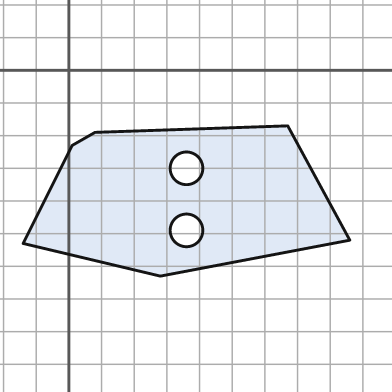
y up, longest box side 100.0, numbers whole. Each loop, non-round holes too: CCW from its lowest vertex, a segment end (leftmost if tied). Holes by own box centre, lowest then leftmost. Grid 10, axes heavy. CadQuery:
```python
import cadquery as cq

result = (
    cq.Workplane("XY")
    .moveTo(28.0, -63.0)
    .lineTo(86.0, -52.0)
    .lineTo(67.0, -17.0)
    .lineTo(8.0, -19.0)
    .lineTo(1.0, -23.0)
    .lineTo(-14.0, -53.0)
    .close()
    .moveTo(36.0, -49.0)
    .circle(5.0)
    .moveTo(36.0, -30.0)
    .circle(5.0)
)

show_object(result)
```